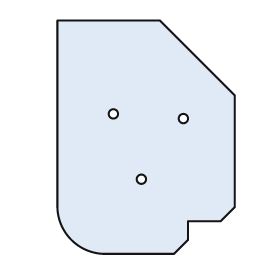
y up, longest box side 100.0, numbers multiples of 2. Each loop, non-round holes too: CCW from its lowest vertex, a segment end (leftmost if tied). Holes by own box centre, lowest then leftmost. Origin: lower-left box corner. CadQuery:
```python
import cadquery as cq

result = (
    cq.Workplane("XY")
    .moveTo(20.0, 0.0)
    .lineTo(50.0, 0.0)
    .lineTo(56.0, 6.0)
    .lineTo(56.0, 14.0)
    .lineTo(70.0, 14.0)
    .lineTo(76.0, 20.0)
    .lineTo(76.0, 68.0)
    .lineTo(44.0, 100.0)
    .lineTo(0.0, 100.0)
    .lineTo(0.0, 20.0)
    .threePointArc((6.0, 6.0), (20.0, 0.0))
    .close()
    .moveTo(36.0, 32.0)
    .circle(2.0)
    .moveTo(54.0, 58.0)
    .circle(2.0)
    .moveTo(24.0, 60.0)
    .circle(2.0)
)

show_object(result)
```